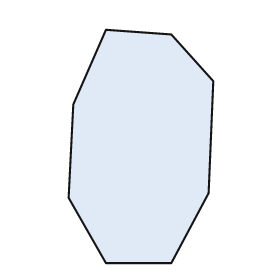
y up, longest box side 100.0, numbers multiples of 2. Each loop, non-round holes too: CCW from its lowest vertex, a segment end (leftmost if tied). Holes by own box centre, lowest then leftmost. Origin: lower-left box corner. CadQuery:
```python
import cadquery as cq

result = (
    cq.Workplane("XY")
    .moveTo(16.0, 0.0)
    .lineTo(44.0, 0.0)
    .lineTo(60.0, 30.0)
    .lineTo(62.0, 78.0)
    .lineTo(44.0, 98.0)
    .lineTo(16.0, 100.0)
    .lineTo(2.0, 68.0)
    .lineTo(0.0, 28.0)
    .close()
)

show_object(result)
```